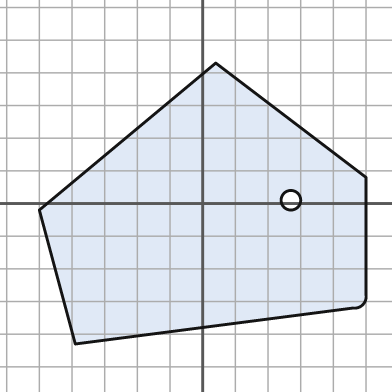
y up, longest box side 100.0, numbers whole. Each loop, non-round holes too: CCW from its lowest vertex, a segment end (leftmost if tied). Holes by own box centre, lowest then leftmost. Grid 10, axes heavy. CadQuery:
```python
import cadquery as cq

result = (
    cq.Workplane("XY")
    .moveTo(-39.0, -43.0)
    .lineTo(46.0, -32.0)
    .threePointArc((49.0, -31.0), (50.0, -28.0))
    .lineTo(50.0, 8.0)
    .lineTo(4.0, 43.0)
    .lineTo(-50.0, -2.0)
    .close()
    .moveTo(27.0, 1.0)
    .circle(3.0)
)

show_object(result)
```